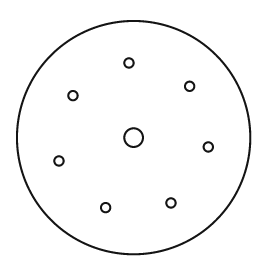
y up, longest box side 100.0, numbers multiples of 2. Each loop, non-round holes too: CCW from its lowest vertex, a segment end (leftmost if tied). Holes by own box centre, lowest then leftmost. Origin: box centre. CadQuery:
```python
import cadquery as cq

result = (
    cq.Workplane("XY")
    .moveTo(0.0, 0.0)
    .circle(50.0)
    .moveTo(-12.0, -30.0)
    .circle(2.0)
    .moveTo(16.0, -28.0)
    .circle(2.0)
    .moveTo(-32.0, -10.0)
    .circle(2.0)
    .moveTo(32.0, -4.0)
    .circle(2.0)
    .moveTo(0.0, 0.0)
    .circle(4.0)
    .moveTo(-26.0, 18.0)
    .circle(2.0)
    .moveTo(24.0, 22.0)
    .circle(2.0)
    .moveTo(-2.0, 32.0)
    .circle(2.0)
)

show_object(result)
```